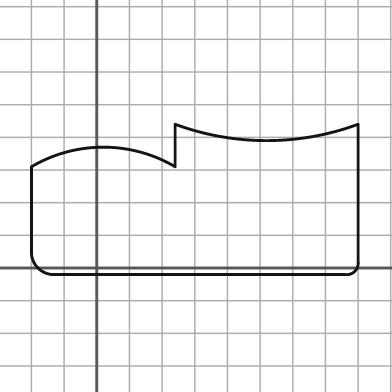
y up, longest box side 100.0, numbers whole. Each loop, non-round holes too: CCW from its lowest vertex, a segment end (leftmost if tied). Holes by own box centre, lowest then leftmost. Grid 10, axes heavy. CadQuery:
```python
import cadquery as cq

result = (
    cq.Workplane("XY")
    .moveTo(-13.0, -2.0)
    .lineTo(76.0, -2.0)
    .threePointArc((79.0, -1.0), (80.0, 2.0))
    .lineTo(80.0, 44.0)
    .threePointArc((52.0, 39.0), (24.0, 44.0))
    .lineTo(24.0, 31.0)
    .threePointArc((2.0, 37.0), (-20.0, 31.0))
    .lineTo(-20.0, 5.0)
    .threePointArc((-18.0, 0.0), (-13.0, -2.0))
    .close()
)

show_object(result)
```